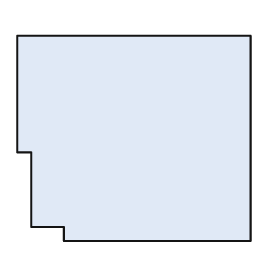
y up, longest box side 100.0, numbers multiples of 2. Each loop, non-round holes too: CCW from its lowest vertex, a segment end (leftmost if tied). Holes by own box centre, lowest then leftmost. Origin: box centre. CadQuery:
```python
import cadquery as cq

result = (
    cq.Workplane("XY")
    .moveTo(-30.0, -44.0)
    .lineTo(50.0, -44.0)
    .lineTo(50.0, 44.0)
    .lineTo(-50.0, 44.0)
    .lineTo(-50.0, -6.0)
    .lineTo(-44.0, -6.0)
    .lineTo(-44.0, -38.0)
    .lineTo(-30.0, -38.0)
    .close()
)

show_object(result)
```